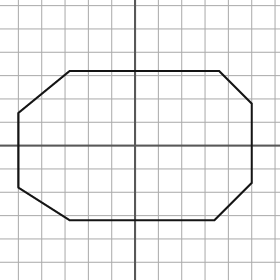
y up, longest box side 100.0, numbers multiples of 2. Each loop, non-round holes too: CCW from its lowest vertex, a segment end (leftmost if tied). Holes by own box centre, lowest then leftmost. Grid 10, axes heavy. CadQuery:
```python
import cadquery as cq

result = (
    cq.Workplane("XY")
    .moveTo(-28.0, -32.0)
    .lineTo(34.0, -32.0)
    .lineTo(50.0, -16.0)
    .lineTo(50.0, 18.0)
    .lineTo(36.0, 32.0)
    .lineTo(-28.0, 32.0)
    .lineTo(-50.0, 14.0)
    .lineTo(-50.0, -18.0)
    .close()
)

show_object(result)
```